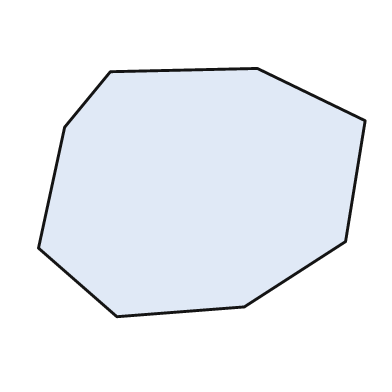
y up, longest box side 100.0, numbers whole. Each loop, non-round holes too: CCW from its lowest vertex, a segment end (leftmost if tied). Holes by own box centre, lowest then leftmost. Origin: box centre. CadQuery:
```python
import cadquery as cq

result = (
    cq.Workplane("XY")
    .moveTo(-26.0, -38.0)
    .lineTo(13.0, -35.0)
    .lineTo(44.0, -15.0)
    .lineTo(50.0, 22.0)
    .lineTo(17.0, 38.0)
    .lineTo(-28.0, 37.0)
    .lineTo(-42.0, 20.0)
    .lineTo(-50.0, -17.0)
    .close()
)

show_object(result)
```